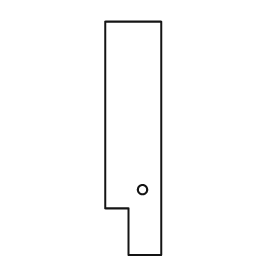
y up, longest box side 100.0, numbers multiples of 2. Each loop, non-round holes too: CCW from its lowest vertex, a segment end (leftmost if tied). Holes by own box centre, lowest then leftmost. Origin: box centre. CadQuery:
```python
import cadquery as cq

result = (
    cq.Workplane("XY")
    .moveTo(-2.0, -50.0)
    .lineTo(12.0, -50.0)
    .lineTo(12.0, 50.0)
    .lineTo(-12.0, 50.0)
    .lineTo(-12.0, -30.0)
    .lineTo(-2.0, -30.0)
    .close()
    .moveTo(4.0, -22.0)
    .circle(2.0)
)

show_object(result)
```